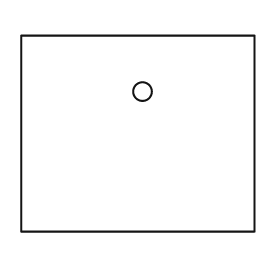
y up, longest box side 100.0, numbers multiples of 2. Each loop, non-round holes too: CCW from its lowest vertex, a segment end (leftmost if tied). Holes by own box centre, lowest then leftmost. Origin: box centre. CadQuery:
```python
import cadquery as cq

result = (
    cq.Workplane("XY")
    .moveTo(-50.0, -42.0)
    .lineTo(50.0, -42.0)
    .lineTo(50.0, 42.0)
    .lineTo(-50.0, 42.0)
    .close()
    .moveTo(2.0, 18.0)
    .circle(4.0)
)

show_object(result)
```